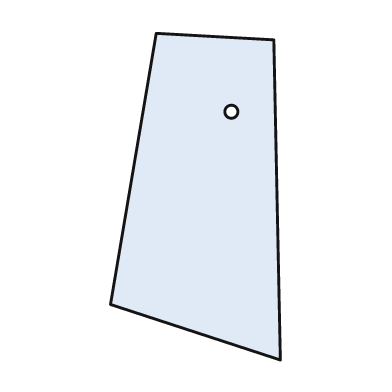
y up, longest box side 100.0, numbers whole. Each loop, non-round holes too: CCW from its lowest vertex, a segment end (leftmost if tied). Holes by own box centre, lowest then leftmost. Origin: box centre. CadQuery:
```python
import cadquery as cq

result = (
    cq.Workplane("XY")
    .moveTo(26.0, -50.0)
    .lineTo(24.0, 48.0)
    .lineTo(-12.0, 50.0)
    .lineTo(-26.0, -33.0)
    .close()
    .moveTo(11.0, 26.0)
    .circle(2.0)
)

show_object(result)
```